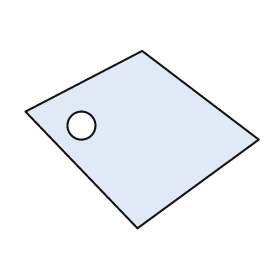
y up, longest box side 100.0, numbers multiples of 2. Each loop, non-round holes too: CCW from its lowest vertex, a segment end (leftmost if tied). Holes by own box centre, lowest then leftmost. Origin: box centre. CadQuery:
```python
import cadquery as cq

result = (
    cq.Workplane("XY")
    .moveTo(-2.0, -38.0)
    .lineTo(50.0, 0.0)
    .lineTo(0.0, 38.0)
    .lineTo(-50.0, 12.0)
    .close()
    .moveTo(-26.0, 6.0)
    .circle(6.0)
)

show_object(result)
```